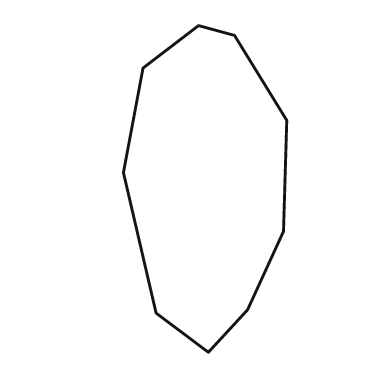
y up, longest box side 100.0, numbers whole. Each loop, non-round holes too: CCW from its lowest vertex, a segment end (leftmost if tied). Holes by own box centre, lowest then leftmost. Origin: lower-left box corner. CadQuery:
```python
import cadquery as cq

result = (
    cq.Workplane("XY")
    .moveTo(26.0, 0.0)
    .lineTo(38.0, 13.0)
    .lineTo(49.0, 37.0)
    .lineTo(50.0, 71.0)
    .lineTo(34.0, 97.0)
    .lineTo(23.0, 100.0)
    .lineTo(6.0, 87.0)
    .lineTo(0.0, 55.0)
    .lineTo(10.0, 12.0)
    .close()
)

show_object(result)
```